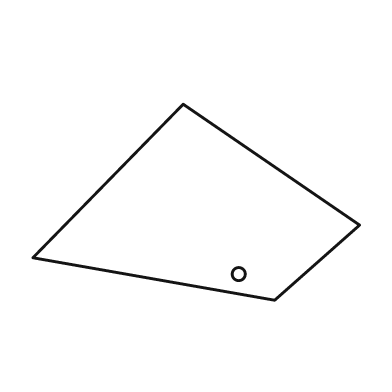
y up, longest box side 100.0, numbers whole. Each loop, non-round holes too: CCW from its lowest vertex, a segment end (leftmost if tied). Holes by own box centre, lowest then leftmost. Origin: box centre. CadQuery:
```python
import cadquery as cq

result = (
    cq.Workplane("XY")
    .moveTo(24.0, -30.0)
    .lineTo(50.0, -7.0)
    .lineTo(-4.0, 30.0)
    .lineTo(-50.0, -17.0)
    .close()
    .moveTo(13.0, -22.0)
    .circle(2.0)
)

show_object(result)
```